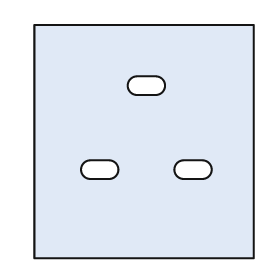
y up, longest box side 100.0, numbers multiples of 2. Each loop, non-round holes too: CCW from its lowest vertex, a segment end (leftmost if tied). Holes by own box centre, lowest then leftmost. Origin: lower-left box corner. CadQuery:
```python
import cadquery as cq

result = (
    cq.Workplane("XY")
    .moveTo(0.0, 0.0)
    .lineTo(94.0, 0.0)
    .lineTo(94.0, 100.0)
    .lineTo(0.0, 100.0)
    .close()
    .moveTo(24.0, 34.0)
    .lineTo(32.0, 34.0)
    .threePointArc((36.0, 38.0), (32.0, 42.0))
    .lineTo(24.0, 42.0)
    .threePointArc((20.0, 38.0), (24.0, 34.0))
    .close()
    .moveTo(64.0, 34.0)
    .lineTo(72.0, 34.0)
    .threePointArc((76.0, 38.0), (72.0, 42.0))
    .lineTo(64.0, 42.0)
    .threePointArc((60.0, 38.0), (64.0, 34.0))
    .close()
    .moveTo(44.0, 70.0)
    .lineTo(52.0, 70.0)
    .threePointArc((56.0, 74.0), (52.0, 78.0))
    .lineTo(44.0, 78.0)
    .threePointArc((40.0, 74.0), (44.0, 70.0))
    .close()
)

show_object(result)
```